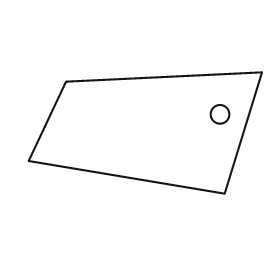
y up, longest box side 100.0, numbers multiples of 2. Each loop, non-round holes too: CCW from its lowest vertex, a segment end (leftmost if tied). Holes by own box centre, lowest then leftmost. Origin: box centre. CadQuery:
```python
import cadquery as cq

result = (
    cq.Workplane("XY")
    .moveTo(34.0, -26.0)
    .lineTo(50.0, 26.0)
    .lineTo(-34.0, 22.0)
    .lineTo(-50.0, -12.0)
    .close()
    .moveTo(32.0, 8.0)
    .circle(4.0)
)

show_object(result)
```